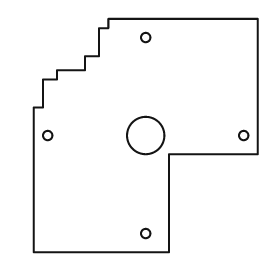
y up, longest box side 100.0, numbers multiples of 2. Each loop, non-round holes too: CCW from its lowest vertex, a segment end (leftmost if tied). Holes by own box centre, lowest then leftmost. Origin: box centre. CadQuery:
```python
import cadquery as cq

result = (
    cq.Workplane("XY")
    .moveTo(-48.0, -50.0)
    .lineTo(10.0, -50.0)
    .lineTo(10.0, -8.0)
    .lineTo(48.0, -8.0)
    .lineTo(48.0, 50.0)
    .lineTo(-16.0, 50.0)
    .lineTo(-16.0, 46.0)
    .lineTo(-20.0, 46.0)
    .lineTo(-20.0, 34.0)
    .lineTo(-26.0, 34.0)
    .lineTo(-26.0, 28.0)
    .lineTo(-38.0, 28.0)
    .lineTo(-38.0, 24.0)
    .lineTo(-44.0, 24.0)
    .lineTo(-44.0, 12.0)
    .lineTo(-48.0, 12.0)
    .close()
    .moveTo(0.0, -42.0)
    .circle(2.0)
    .moveTo(-42.0, 0.0)
    .circle(2.0)
    .moveTo(0.0, 0.0)
    .circle(8.0)
    .moveTo(42.0, 0.0)
    .circle(2.0)
    .moveTo(0.0, 42.0)
    .circle(2.0)
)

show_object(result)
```